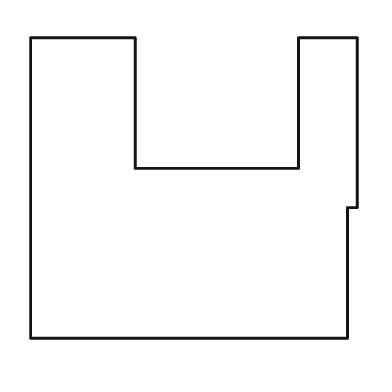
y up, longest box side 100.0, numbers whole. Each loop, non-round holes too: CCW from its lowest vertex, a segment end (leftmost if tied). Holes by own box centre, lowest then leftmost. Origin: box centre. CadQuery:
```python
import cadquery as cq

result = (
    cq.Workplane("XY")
    .moveTo(-50.0, -46.0)
    .lineTo(47.0, -46.0)
    .lineTo(47.0, -6.0)
    .lineTo(50.0, -6.0)
    .lineTo(50.0, 46.0)
    .lineTo(32.0, 46.0)
    .lineTo(32.0, 6.0)
    .lineTo(-18.0, 6.0)
    .lineTo(-18.0, 46.0)
    .lineTo(-50.0, 46.0)
    .close()
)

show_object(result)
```